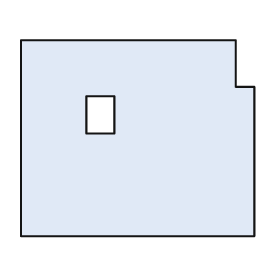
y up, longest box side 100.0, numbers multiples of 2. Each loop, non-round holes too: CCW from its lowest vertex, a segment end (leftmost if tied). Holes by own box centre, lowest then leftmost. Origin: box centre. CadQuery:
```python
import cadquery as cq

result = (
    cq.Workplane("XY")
    .moveTo(-50.0, -42.0)
    .lineTo(50.0, -42.0)
    .lineTo(50.0, 22.0)
    .lineTo(42.0, 22.0)
    .lineTo(42.0, 42.0)
    .lineTo(-50.0, 42.0)
    .close()
    .moveTo(-22.0, 2.0)
    .lineTo(-10.0, 2.0)
    .lineTo(-10.0, 18.0)
    .lineTo(-22.0, 18.0)
    .close()
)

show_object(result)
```